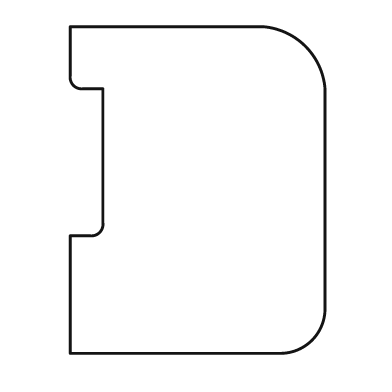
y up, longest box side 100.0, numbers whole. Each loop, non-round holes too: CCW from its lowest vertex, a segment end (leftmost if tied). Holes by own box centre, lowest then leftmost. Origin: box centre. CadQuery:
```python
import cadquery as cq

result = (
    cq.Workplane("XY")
    .moveTo(-39.0, -50.0)
    .lineTo(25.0, -50.0)
    .threePointArc((35.0, -46.0), (39.0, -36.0))
    .lineTo(39.0, 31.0)
    .threePointArc((33.0, 44.0), (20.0, 50.0))
    .lineTo(-39.0, 50.0)
    .lineTo(-39.0, 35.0)
    .threePointArc((-38.0, 32.0), (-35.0, 31.0))
    .lineTo(-29.0, 31.0)
    .lineTo(-29.0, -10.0)
    .threePointArc((-30.0, -13.0), (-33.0, -14.0))
    .lineTo(-39.0, -14.0)
    .close()
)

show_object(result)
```